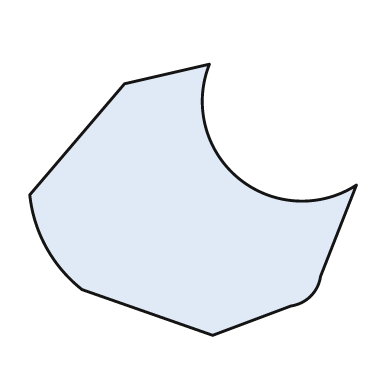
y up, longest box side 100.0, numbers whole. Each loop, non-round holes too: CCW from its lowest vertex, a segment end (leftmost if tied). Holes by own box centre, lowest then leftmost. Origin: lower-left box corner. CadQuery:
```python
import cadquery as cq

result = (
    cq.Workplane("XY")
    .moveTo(56.0, 0.0)
    .lineTo(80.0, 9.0)
    .threePointArc((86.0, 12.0), (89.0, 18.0))
    .lineTo(100.0, 46.0)
    .threePointArc((64.0, 48.0), (55.0, 83.0))
    .lineTo(29.0, 77.0)
    .lineTo(0.0, 43.0)
    .threePointArc((5.0, 27.0), (16.0, 14.0))
    .close()
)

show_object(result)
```